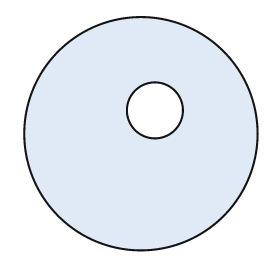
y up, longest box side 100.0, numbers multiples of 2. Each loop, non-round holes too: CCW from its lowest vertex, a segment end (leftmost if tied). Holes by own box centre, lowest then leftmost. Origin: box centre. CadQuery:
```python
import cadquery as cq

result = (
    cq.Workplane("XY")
    .moveTo(0.0, 0.0)
    .circle(50.0)
    .moveTo(6.0, 10.0)
    .circle(12.0)
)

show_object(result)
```